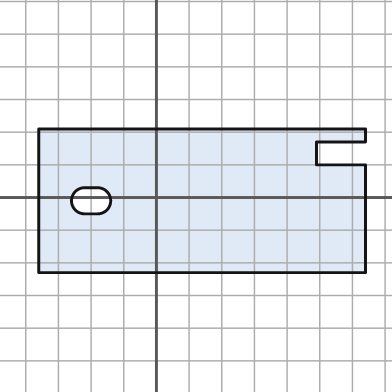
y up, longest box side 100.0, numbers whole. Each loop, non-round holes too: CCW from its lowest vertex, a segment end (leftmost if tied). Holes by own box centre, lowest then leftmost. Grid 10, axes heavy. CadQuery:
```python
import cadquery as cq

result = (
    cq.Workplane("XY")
    .moveTo(-36.0, -23.0)
    .lineTo(64.0, -23.0)
    .lineTo(64.0, 10.0)
    .lineTo(49.0, 10.0)
    .lineTo(49.0, 17.0)
    .lineTo(64.0, 17.0)
    .lineTo(64.0, 21.0)
    .lineTo(-36.0, 21.0)
    .close()
    .moveTo(-22.0, -5.0)
    .lineTo(-18.0, -5.0)
    .threePointArc((-14.0, -1.0), (-18.0, 3.0))
    .lineTo(-22.0, 3.0)
    .threePointArc((-26.0, -1.0), (-22.0, -5.0))
    .close()
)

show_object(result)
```